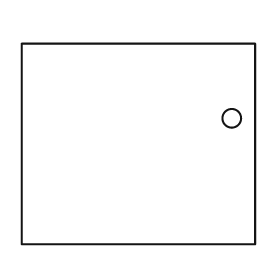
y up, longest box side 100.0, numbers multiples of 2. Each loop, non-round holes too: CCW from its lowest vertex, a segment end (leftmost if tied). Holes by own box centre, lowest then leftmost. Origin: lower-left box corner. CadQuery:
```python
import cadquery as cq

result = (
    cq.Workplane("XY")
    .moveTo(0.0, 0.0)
    .lineTo(100.0, 0.0)
    .lineTo(100.0, 86.0)
    .lineTo(0.0, 86.0)
    .close()
    .moveTo(90.0, 54.0)
    .circle(4.0)
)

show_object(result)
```